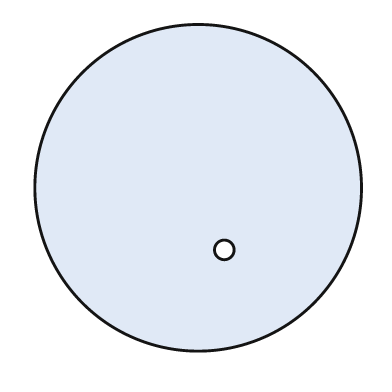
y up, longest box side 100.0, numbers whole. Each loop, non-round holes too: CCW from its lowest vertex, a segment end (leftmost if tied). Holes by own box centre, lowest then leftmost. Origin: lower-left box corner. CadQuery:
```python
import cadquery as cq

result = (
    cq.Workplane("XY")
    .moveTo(50.0, 50.0)
    .circle(50.0)
    .moveTo(58.0, 31.0)
    .circle(3.0)
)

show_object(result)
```